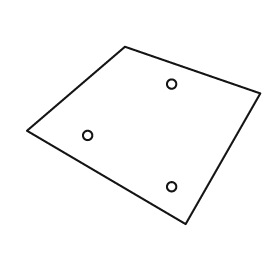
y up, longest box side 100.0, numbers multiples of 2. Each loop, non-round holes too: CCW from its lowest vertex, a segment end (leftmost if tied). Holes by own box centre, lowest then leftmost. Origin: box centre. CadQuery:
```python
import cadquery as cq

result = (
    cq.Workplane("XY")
    .moveTo(18.0, -38.0)
    .lineTo(50.0, 18.0)
    .lineTo(-8.0, 38.0)
    .lineTo(-50.0, 2.0)
    .close()
    .moveTo(12.0, -22.0)
    .circle(2.0)
    .moveTo(-24.0, 0.0)
    .circle(2.0)
    .moveTo(12.0, 22.0)
    .circle(2.0)
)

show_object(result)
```